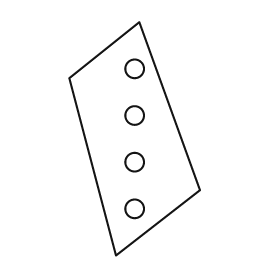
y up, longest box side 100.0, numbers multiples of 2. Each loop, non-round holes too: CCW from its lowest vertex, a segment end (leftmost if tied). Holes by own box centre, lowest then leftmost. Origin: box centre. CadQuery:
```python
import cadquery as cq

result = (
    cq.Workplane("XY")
    .moveTo(-8.0, -50.0)
    .lineTo(28.0, -22.0)
    .lineTo(2.0, 50.0)
    .lineTo(-28.0, 26.0)
    .close()
    .moveTo(0.0, -30.0)
    .circle(4.0)
    .moveTo(0.0, -10.0)
    .circle(4.0)
    .moveTo(0.0, 10.0)
    .circle(4.0)
    .moveTo(0.0, 30.0)
    .circle(4.0)
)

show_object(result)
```